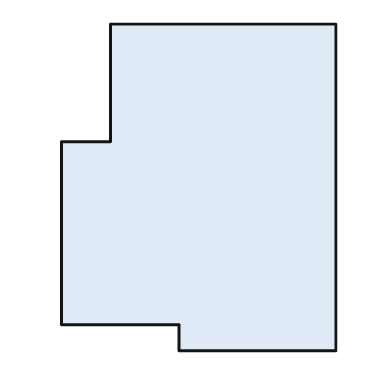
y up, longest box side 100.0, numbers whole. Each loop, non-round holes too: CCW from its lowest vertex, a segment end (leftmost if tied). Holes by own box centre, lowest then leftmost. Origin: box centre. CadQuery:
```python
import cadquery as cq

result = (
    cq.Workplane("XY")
    .moveTo(-6.0, -50.0)
    .lineTo(42.0, -50.0)
    .lineTo(42.0, 50.0)
    .lineTo(-27.0, 50.0)
    .lineTo(-27.0, 14.0)
    .lineTo(-42.0, 14.0)
    .lineTo(-42.0, -42.0)
    .lineTo(-6.0, -42.0)
    .close()
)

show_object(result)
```